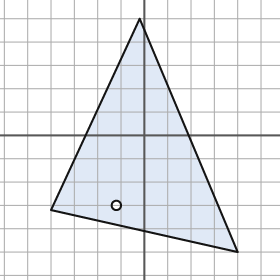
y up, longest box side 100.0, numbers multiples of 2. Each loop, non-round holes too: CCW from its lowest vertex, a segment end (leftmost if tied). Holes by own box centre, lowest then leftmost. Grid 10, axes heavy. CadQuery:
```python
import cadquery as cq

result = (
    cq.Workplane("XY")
    .moveTo(40.0, -50.0)
    .lineTo(-2.0, 50.0)
    .lineTo(-40.0, -32.0)
    .close()
    .moveTo(-12.0, -30.0)
    .circle(2.0)
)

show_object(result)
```